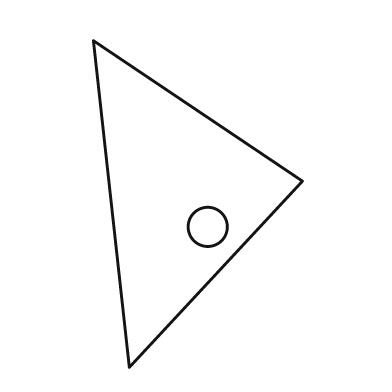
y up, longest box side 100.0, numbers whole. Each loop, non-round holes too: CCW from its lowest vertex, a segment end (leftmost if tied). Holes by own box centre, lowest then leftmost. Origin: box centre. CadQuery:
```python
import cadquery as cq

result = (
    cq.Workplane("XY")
    .moveTo(-21.0, -50.0)
    .lineTo(32.0, 7.0)
    .lineTo(-32.0, 50.0)
    .close()
    .moveTo(3.0, -7.0)
    .circle(6.0)
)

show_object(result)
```